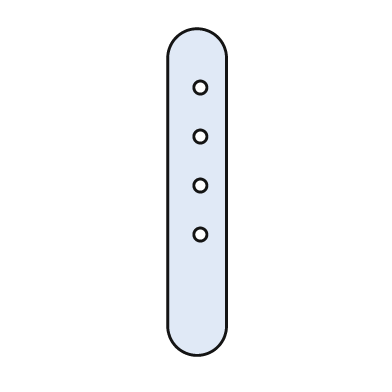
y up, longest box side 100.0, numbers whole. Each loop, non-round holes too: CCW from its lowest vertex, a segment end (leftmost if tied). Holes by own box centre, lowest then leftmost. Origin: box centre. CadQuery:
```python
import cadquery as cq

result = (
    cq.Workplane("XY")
    .moveTo(-9.0, -41.0)
    .threePointArc((0.0, -50.0), (9.0, -41.0))
    .lineTo(9.0, 41.0)
    .threePointArc((0.0, 50.0), (-9.0, 41.0))
    .close()
    .moveTo(1.0, -13.0)
    .circle(2.0)
    .moveTo(1.0, 2.0)
    .circle(2.0)
    .moveTo(1.0, 17.0)
    .circle(2.0)
    .moveTo(1.0, 32.0)
    .circle(2.0)
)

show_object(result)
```